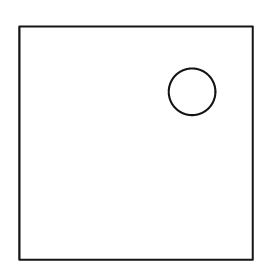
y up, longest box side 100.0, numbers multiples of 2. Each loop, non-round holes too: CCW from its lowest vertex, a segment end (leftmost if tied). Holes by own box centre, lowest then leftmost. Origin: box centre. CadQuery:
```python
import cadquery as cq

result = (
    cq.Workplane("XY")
    .moveTo(-50.0, -50.0)
    .lineTo(50.0, -50.0)
    .lineTo(50.0, 50.0)
    .lineTo(-50.0, 50.0)
    .close()
    .moveTo(24.0, 22.0)
    .circle(10.0)
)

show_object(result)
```